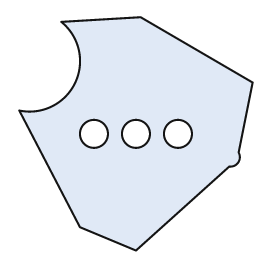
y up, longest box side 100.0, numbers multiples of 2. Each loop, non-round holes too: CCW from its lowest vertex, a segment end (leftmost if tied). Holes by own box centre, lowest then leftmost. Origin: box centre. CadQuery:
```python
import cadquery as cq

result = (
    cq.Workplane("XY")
    .moveTo(0.0, -50.0)
    .lineTo(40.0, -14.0)
    .threePointArc((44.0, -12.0), (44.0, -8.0))
    .lineTo(50.0, 22.0)
    .lineTo(2.0, 50.0)
    .lineTo(-32.0, 48.0)
    .threePointArc((-26.0, 22.0), (-50.0, 10.0))
    .lineTo(-24.0, -40.0)
    .close()
    .moveTo(-18.0, 0.0)
    .circle(6.0)
    .moveTo(0.0, 0.0)
    .circle(6.0)
    .moveTo(18.0, 0.0)
    .circle(6.0)
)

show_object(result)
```